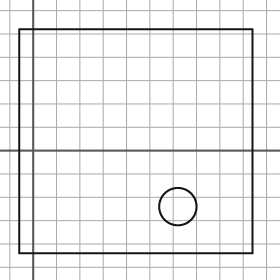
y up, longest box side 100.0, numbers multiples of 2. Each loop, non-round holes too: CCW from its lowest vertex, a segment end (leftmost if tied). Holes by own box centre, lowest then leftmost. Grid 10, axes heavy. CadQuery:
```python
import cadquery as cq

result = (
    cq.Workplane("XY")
    .moveTo(-6.0, -44.0)
    .lineTo(94.0, -44.0)
    .lineTo(94.0, 52.0)
    .lineTo(-6.0, 52.0)
    .close()
    .moveTo(62.0, -24.0)
    .circle(8.0)
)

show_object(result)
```